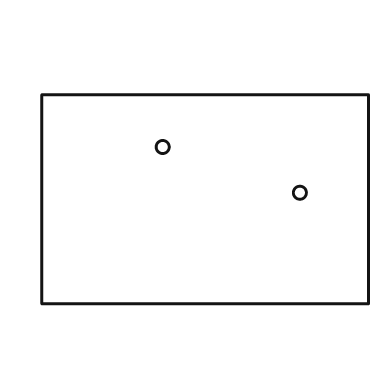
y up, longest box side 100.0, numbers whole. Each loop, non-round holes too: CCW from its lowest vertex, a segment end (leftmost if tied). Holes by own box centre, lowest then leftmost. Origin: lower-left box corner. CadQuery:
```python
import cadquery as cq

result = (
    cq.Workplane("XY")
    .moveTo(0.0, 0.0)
    .lineTo(100.0, 0.0)
    .lineTo(100.0, 64.0)
    .lineTo(0.0, 64.0)
    .close()
    .moveTo(79.0, 34.0)
    .circle(2.0)
    .moveTo(37.0, 48.0)
    .circle(2.0)
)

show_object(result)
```